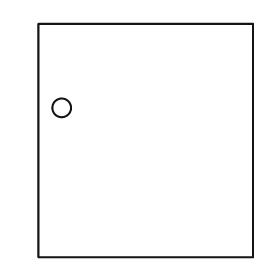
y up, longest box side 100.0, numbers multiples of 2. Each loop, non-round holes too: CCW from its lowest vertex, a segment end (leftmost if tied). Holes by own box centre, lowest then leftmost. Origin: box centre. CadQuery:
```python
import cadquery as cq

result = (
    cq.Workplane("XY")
    .moveTo(-46.0, -50.0)
    .lineTo(46.0, -50.0)
    .lineTo(46.0, 50.0)
    .lineTo(-46.0, 50.0)
    .close()
    .moveTo(-36.0, 14.0)
    .circle(4.0)
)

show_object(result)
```